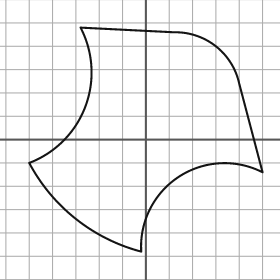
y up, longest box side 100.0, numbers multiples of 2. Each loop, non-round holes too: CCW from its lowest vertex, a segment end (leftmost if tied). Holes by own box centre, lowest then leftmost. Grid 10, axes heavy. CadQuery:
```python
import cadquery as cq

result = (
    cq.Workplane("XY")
    .moveTo(-2.0, -48.0)
    .threePointArc((14.0, -16.0), (50.0, -14.0))
    .lineTo(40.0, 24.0)
    .threePointArc((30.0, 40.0), (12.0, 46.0))
    .lineTo(-28.0, 48.0)
    .threePointArc((-26.0, 14.0), (-50.0, -10.0))
    .threePointArc((-30.0, -34.0), (-2.0, -48.0))
    .close()
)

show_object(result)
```